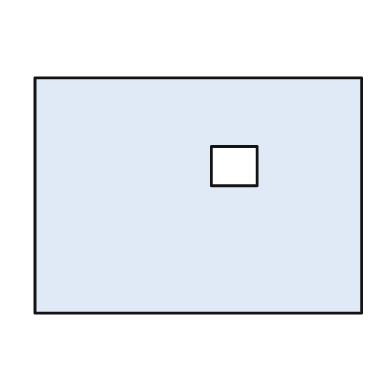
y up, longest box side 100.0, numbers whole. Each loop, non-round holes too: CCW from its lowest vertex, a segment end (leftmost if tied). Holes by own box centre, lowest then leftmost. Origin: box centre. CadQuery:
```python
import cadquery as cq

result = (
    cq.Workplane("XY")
    .moveTo(-50.0, -36.0)
    .lineTo(50.0, -36.0)
    .lineTo(50.0, 36.0)
    .lineTo(-50.0, 36.0)
    .close()
    .moveTo(4.0, 3.0)
    .lineTo(18.0, 3.0)
    .lineTo(18.0, 15.0)
    .lineTo(4.0, 15.0)
    .close()
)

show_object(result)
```